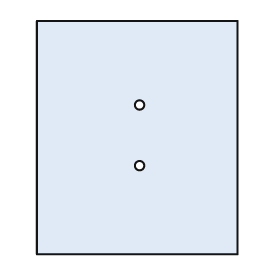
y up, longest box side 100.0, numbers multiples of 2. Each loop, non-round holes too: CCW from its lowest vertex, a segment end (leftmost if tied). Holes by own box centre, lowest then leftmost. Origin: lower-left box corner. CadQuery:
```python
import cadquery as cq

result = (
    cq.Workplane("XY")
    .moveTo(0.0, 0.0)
    .lineTo(86.0, 0.0)
    .lineTo(86.0, 100.0)
    .lineTo(0.0, 100.0)
    .close()
    .moveTo(44.0, 38.0)
    .circle(2.0)
    .moveTo(44.0, 64.0)
    .circle(2.0)
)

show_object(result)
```